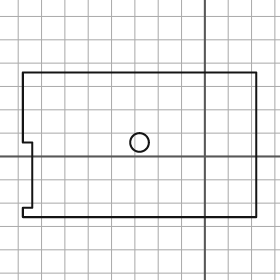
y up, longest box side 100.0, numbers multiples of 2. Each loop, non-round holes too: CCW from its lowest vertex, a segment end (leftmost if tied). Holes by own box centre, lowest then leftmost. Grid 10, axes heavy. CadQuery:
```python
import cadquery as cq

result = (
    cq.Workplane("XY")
    .moveTo(-78.0, -26.0)
    .lineTo(22.0, -26.0)
    .lineTo(22.0, 36.0)
    .lineTo(-78.0, 36.0)
    .lineTo(-78.0, 6.0)
    .lineTo(-74.0, 6.0)
    .lineTo(-74.0, -22.0)
    .lineTo(-78.0, -22.0)
    .close()
    .moveTo(-28.0, 6.0)
    .circle(4.0)
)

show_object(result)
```